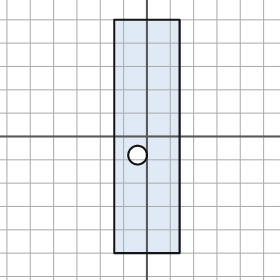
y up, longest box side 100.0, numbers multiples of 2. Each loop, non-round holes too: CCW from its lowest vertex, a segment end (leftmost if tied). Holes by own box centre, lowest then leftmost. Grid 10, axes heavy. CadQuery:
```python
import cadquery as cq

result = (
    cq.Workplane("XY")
    .moveTo(-14.0, -50.0)
    .lineTo(14.0, -50.0)
    .lineTo(14.0, 50.0)
    .lineTo(-14.0, 50.0)
    .close()
    .moveTo(-4.0, -8.0)
    .circle(4.0)
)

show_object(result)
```